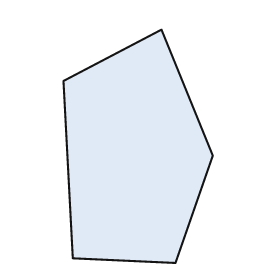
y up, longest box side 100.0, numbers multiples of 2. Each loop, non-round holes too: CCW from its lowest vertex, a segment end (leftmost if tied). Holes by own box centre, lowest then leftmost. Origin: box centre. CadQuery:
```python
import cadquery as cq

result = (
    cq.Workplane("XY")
    .moveTo(16.0, -50.0)
    .lineTo(32.0, -4.0)
    .lineTo(10.0, 50.0)
    .lineTo(-32.0, 28.0)
    .lineTo(-28.0, -48.0)
    .close()
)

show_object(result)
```